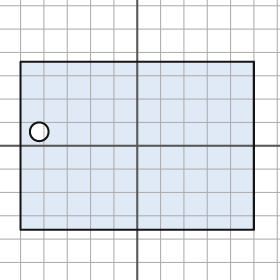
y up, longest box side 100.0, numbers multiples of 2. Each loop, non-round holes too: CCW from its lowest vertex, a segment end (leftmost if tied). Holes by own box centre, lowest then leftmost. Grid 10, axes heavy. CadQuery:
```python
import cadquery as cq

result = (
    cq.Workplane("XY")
    .moveTo(-50.0, -36.0)
    .lineTo(50.0, -36.0)
    .lineTo(50.0, 36.0)
    .lineTo(-50.0, 36.0)
    .close()
    .moveTo(-42.0, 6.0)
    .circle(4.0)
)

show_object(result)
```